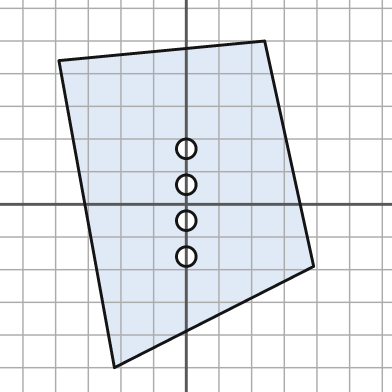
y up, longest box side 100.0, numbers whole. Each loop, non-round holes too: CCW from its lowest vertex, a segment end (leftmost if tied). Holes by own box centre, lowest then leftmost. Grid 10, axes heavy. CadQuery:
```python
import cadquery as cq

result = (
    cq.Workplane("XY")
    .moveTo(-22.0, -50.0)
    .lineTo(39.0, -19.0)
    .lineTo(24.0, 50.0)
    .lineTo(-39.0, 44.0)
    .close()
    .moveTo(0.0, -16.0)
    .circle(3.0)
    .moveTo(0.0, -5.0)
    .circle(3.0)
    .moveTo(0.0, 6.0)
    .circle(3.0)
    .moveTo(0.0, 17.0)
    .circle(3.0)
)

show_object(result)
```